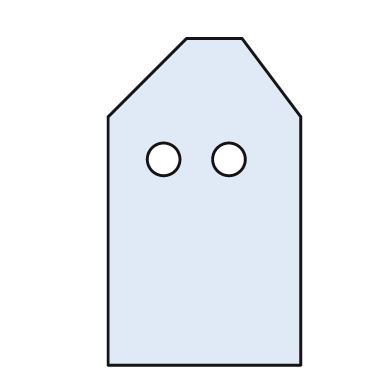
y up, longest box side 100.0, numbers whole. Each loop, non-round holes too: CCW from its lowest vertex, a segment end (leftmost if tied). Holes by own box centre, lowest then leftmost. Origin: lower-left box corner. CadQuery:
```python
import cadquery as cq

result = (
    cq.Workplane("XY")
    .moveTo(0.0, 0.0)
    .lineTo(59.0, 0.0)
    .lineTo(59.0, 76.0)
    .lineTo(41.0, 100.0)
    .lineTo(24.0, 100.0)
    .lineTo(0.0, 76.0)
    .close()
    .moveTo(17.0, 63.0)
    .circle(5.0)
    .moveTo(37.0, 63.0)
    .circle(5.0)
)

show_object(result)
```